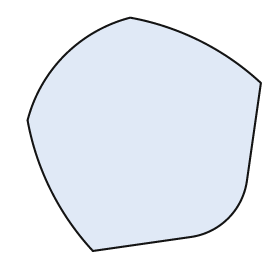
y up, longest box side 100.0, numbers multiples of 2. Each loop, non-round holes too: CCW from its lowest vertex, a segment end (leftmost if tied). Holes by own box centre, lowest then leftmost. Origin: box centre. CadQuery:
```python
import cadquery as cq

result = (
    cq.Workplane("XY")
    .moveTo(-22.0, -50.0)
    .lineTo(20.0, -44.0)
    .threePointArc((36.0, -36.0), (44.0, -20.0))
    .lineTo(50.0, 22.0)
    .threePointArc((24.0, 40.0), (-6.0, 50.0))
    .threePointArc((-34.0, 34.0), (-50.0, 6.0))
    .threePointArc((-40.0, -24.0), (-22.0, -50.0))
    .close()
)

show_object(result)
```